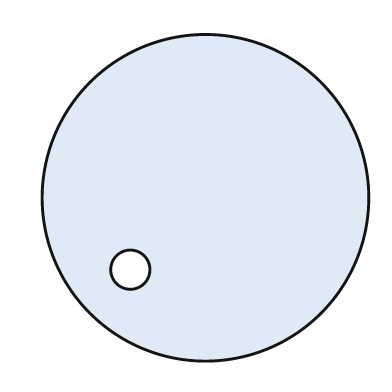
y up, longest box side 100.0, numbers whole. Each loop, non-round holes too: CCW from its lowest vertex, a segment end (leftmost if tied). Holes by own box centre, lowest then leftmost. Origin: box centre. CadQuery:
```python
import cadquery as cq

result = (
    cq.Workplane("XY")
    .moveTo(0.0, 0.0)
    .circle(50.0)
    .moveTo(-23.0, -22.0)
    .circle(6.0)
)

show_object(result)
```